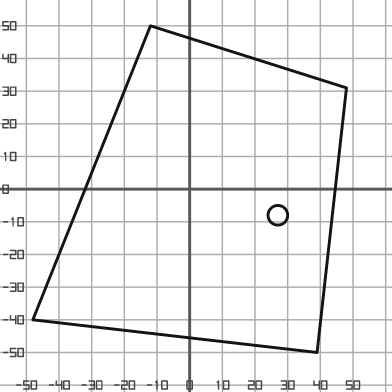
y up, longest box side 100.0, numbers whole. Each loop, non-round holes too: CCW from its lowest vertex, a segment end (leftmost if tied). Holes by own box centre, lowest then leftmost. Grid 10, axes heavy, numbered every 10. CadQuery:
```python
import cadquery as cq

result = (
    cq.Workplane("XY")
    .moveTo(39.0, -50.0)
    .lineTo(48.0, 31.0)
    .lineTo(-12.0, 50.0)
    .lineTo(-48.0, -40.0)
    .close()
    .moveTo(27.0, -8.0)
    .circle(3.0)
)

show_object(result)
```